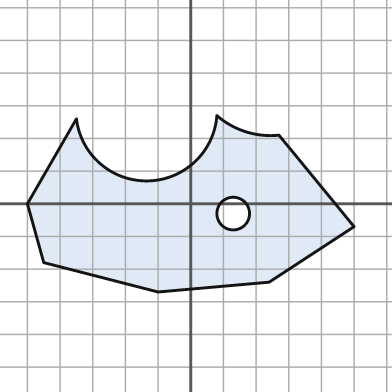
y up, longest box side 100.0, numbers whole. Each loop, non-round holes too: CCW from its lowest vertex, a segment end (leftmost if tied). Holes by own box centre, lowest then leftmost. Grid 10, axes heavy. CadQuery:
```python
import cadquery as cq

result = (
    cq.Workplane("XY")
    .moveTo(-10.0, -27.0)
    .lineTo(24.0, -24.0)
    .lineTo(50.0, -7.0)
    .lineTo(27.0, 21.0)
    .threePointArc((17.0, 22.0), (8.0, 27.0))
    .threePointArc((-13.0, 7.0), (-35.0, 26.0))
    .lineTo(-50.0, 0.0)
    .lineTo(-45.0, -18.0)
    .close()
    .moveTo(13.0, -3.0)
    .circle(5.0)
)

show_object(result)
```